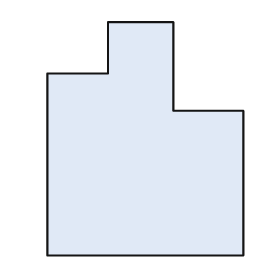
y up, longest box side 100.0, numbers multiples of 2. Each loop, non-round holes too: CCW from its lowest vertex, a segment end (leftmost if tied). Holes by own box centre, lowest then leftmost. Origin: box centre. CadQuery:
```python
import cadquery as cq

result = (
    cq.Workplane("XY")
    .moveTo(-42.0, -50.0)
    .lineTo(42.0, -50.0)
    .lineTo(42.0, 12.0)
    .lineTo(12.0, 12.0)
    .lineTo(12.0, 50.0)
    .lineTo(-16.0, 50.0)
    .lineTo(-16.0, 28.0)
    .lineTo(-42.0, 28.0)
    .close()
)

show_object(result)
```